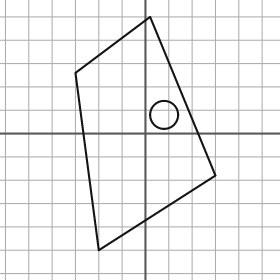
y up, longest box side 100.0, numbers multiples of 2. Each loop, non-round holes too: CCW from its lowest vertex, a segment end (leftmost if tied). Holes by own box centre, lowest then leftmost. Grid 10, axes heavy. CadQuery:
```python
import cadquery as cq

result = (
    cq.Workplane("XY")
    .moveTo(-20.0, -50.0)
    .lineTo(30.0, -18.0)
    .lineTo(2.0, 50.0)
    .lineTo(-30.0, 26.0)
    .close()
    .moveTo(8.0, 8.0)
    .circle(6.0)
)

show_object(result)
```